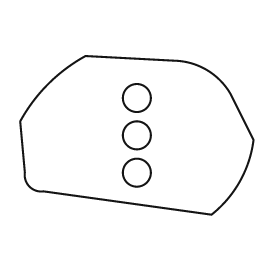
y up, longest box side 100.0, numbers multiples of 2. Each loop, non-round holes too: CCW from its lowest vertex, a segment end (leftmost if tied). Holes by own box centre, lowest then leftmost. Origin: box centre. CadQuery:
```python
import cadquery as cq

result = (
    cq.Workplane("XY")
    .moveTo(32.0, -34.0)
    .threePointArc((44.0, -20.0), (50.0, -2.0))
    .lineTo(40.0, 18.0)
    .threePointArc((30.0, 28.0), (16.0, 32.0))
    .lineTo(-22.0, 34.0)
    .threePointArc((-38.0, 22.0), (-50.0, 6.0))
    .lineTo(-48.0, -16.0)
    .threePointArc((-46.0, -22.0), (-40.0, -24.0))
    .close()
    .moveTo(0.0, -16.0)
    .circle(6.0)
    .moveTo(0.0, 0.0)
    .circle(6.0)
    .moveTo(0.0, 16.0)
    .circle(6.0)
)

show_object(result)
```